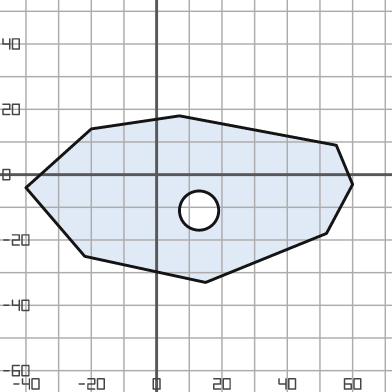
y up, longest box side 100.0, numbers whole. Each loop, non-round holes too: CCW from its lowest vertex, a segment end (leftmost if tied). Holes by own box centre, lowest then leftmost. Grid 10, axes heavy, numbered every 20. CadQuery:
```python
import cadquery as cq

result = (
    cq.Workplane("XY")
    .moveTo(15.0, -33.0)
    .lineTo(52.0, -18.0)
    .lineTo(60.0, -3.0)
    .lineTo(55.0, 9.0)
    .lineTo(7.0, 18.0)
    .lineTo(-20.0, 14.0)
    .lineTo(-40.0, -4.0)
    .lineTo(-22.0, -25.0)
    .close()
    .moveTo(13.0, -11.0)
    .circle(6.0)
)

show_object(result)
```